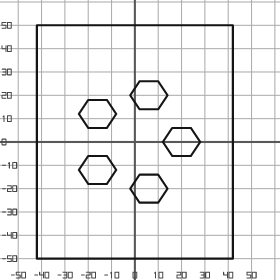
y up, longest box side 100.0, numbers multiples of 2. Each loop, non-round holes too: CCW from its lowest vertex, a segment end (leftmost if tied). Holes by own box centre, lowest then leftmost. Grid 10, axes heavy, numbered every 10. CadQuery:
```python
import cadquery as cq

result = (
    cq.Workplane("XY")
    .moveTo(-42.0, -50.0)
    .lineTo(42.0, -50.0)
    .lineTo(42.0, 50.0)
    .lineTo(-42.0, 50.0)
    .close()
    .moveTo(2.0, -26.0)
    .lineTo(10.0, -26.0)
    .lineTo(14.0, -20.0)
    .lineTo(10.0, -14.0)
    .lineTo(2.0, -14.0)
    .lineTo(-2.0, -20.0)
    .close()
    .moveTo(-20.0, -18.0)
    .lineTo(-12.0, -18.0)
    .lineTo(-8.0, -12.0)
    .lineTo(-12.0, -6.0)
    .lineTo(-20.0, -6.0)
    .lineTo(-24.0, -12.0)
    .close()
    .moveTo(16.0, -6.0)
    .lineTo(24.0, -6.0)
    .lineTo(28.0, 0.0)
    .lineTo(24.0, 6.0)
    .lineTo(16.0, 6.0)
    .lineTo(12.0, 0.0)
    .close()
    .moveTo(-20.0, 6.0)
    .lineTo(-12.0, 6.0)
    .lineTo(-8.0, 12.0)
    .lineTo(-12.0, 18.0)
    .lineTo(-20.0, 18.0)
    .lineTo(-24.0, 12.0)
    .close()
    .moveTo(2.0, 14.0)
    .lineTo(10.0, 14.0)
    .lineTo(14.0, 20.0)
    .lineTo(10.0, 26.0)
    .lineTo(2.0, 26.0)
    .lineTo(-2.0, 20.0)
    .close()
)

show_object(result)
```